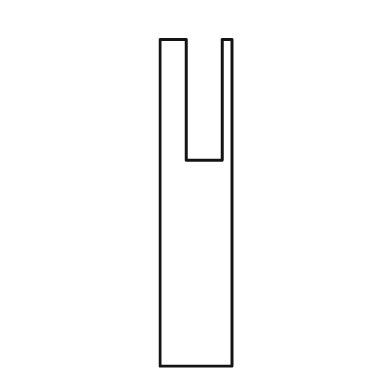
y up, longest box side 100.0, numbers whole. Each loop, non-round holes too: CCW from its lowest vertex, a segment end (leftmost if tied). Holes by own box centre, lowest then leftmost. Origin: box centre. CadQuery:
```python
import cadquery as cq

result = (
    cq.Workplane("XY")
    .moveTo(-11.0, -50.0)
    .lineTo(11.0, -50.0)
    .lineTo(11.0, 50.0)
    .lineTo(8.0, 50.0)
    .lineTo(8.0, 13.0)
    .lineTo(-3.0, 13.0)
    .lineTo(-3.0, 50.0)
    .lineTo(-11.0, 50.0)
    .close()
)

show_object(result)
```